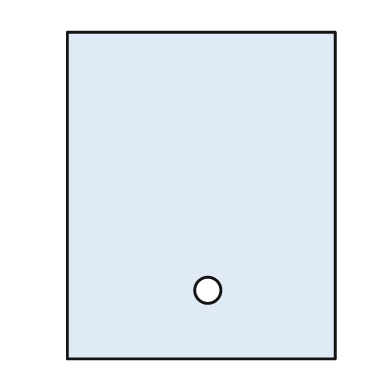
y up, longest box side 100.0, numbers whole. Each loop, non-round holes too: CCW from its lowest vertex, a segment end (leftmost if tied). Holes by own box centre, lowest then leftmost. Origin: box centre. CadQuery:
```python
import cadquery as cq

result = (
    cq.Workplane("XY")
    .moveTo(-41.0, -50.0)
    .lineTo(41.0, -50.0)
    .lineTo(41.0, 50.0)
    .lineTo(-41.0, 50.0)
    .close()
    .moveTo(2.0, -29.0)
    .circle(4.0)
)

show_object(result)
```